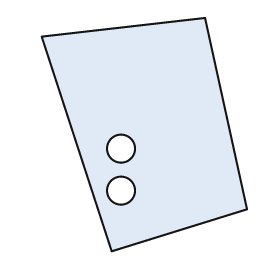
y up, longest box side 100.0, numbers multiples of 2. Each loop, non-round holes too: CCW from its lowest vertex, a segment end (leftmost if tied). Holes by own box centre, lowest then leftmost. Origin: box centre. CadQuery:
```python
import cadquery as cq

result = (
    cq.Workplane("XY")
    .moveTo(-14.0, -50.0)
    .lineTo(44.0, -32.0)
    .lineTo(26.0, 50.0)
    .lineTo(-44.0, 42.0)
    .close()
    .moveTo(-10.0, -24.0)
    .circle(6.0)
    .moveTo(-10.0, -6.0)
    .circle(6.0)
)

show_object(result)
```